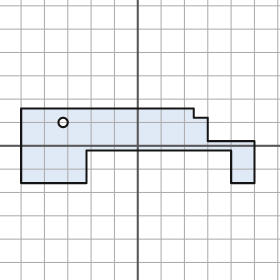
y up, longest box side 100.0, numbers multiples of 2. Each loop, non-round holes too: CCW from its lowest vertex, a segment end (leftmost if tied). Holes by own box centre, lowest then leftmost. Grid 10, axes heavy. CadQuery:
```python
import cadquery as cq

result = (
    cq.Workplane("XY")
    .moveTo(-50.0, -16.0)
    .lineTo(-22.0, -16.0)
    .lineTo(-22.0, -2.0)
    .lineTo(40.0, -2.0)
    .lineTo(40.0, -16.0)
    .lineTo(50.0, -16.0)
    .lineTo(50.0, 2.0)
    .lineTo(30.0, 2.0)
    .lineTo(30.0, 12.0)
    .lineTo(24.0, 12.0)
    .lineTo(24.0, 16.0)
    .lineTo(-50.0, 16.0)
    .close()
    .moveTo(-32.0, 10.0)
    .circle(2.0)
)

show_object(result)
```